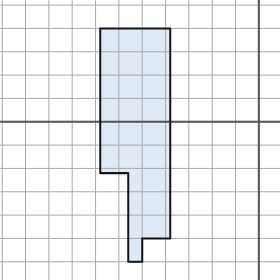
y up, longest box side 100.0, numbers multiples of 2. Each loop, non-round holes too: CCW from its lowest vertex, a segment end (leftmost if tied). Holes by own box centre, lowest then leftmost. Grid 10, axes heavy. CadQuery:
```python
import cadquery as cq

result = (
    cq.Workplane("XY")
    .moveTo(-56.0, -60.0)
    .lineTo(-50.0, -60.0)
    .lineTo(-50.0, -50.0)
    .lineTo(-38.0, -50.0)
    .lineTo(-38.0, 40.0)
    .lineTo(-68.0, 40.0)
    .lineTo(-68.0, -22.0)
    .lineTo(-56.0, -22.0)
    .close()
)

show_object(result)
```